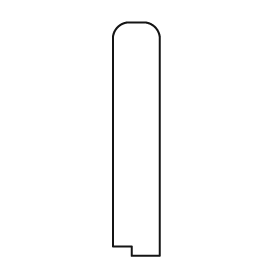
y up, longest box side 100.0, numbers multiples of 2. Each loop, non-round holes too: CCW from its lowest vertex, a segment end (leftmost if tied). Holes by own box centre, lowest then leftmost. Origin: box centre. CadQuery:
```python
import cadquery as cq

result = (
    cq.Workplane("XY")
    .moveTo(-2.0, -50.0)
    .lineTo(10.0, -50.0)
    .lineTo(10.0, 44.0)
    .threePointArc((8.0, 48.0), (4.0, 50.0))
    .lineTo(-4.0, 50.0)
    .threePointArc((-8.0, 48.0), (-10.0, 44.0))
    .lineTo(-10.0, -46.0)
    .lineTo(-2.0, -46.0)
    .close()
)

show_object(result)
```